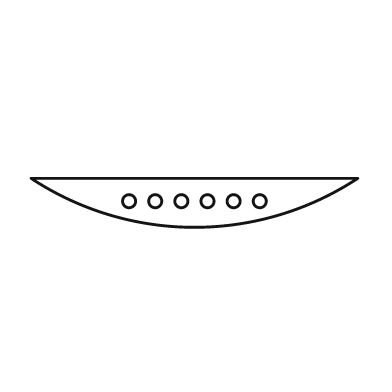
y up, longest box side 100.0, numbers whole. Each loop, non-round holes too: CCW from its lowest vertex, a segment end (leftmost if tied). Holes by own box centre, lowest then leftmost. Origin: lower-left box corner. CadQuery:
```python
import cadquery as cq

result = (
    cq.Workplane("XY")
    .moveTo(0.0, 15.0)
    .threePointArc((50.0, 0.0), (100.0, 15.0))
    .close()
    .moveTo(30.0, 8.0)
    .circle(2.0)
    .moveTo(38.0, 8.0)
    .circle(2.0)
    .moveTo(46.0, 8.0)
    .circle(2.0)
    .moveTo(54.0, 8.0)
    .circle(2.0)
    .moveTo(62.0, 8.0)
    .circle(2.0)
    .moveTo(70.0, 8.0)
    .circle(2.0)
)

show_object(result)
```